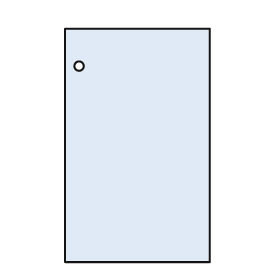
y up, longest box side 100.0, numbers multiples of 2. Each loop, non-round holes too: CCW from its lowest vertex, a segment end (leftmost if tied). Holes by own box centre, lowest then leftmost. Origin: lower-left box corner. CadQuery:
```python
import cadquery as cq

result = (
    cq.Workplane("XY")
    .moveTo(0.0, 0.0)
    .lineTo(62.0, 0.0)
    .lineTo(62.0, 100.0)
    .lineTo(0.0, 100.0)
    .close()
    .moveTo(6.0, 84.0)
    .circle(2.0)
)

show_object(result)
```